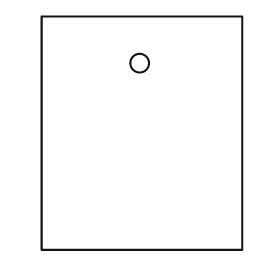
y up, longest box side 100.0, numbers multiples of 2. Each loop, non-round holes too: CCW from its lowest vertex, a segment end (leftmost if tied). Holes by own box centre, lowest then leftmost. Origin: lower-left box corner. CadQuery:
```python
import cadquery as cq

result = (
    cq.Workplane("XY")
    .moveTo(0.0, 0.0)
    .lineTo(86.0, 0.0)
    .lineTo(86.0, 100.0)
    .lineTo(0.0, 100.0)
    .close()
    .moveTo(42.0, 80.0)
    .circle(4.0)
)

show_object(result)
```